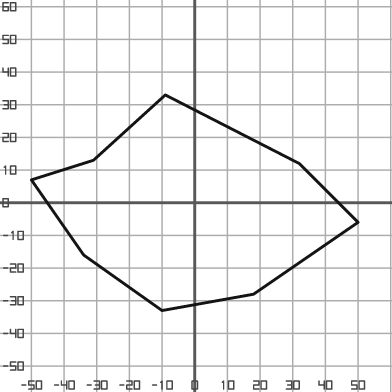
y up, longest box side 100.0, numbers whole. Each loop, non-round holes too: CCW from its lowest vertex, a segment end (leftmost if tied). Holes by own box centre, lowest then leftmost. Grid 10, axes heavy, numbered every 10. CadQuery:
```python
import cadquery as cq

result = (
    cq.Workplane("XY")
    .moveTo(-10.0, -33.0)
    .lineTo(18.0, -28.0)
    .lineTo(50.0, -6.0)
    .lineTo(32.0, 12.0)
    .lineTo(-9.0, 33.0)
    .lineTo(-31.0, 13.0)
    .lineTo(-50.0, 7.0)
    .lineTo(-34.0, -16.0)
    .close()
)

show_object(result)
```